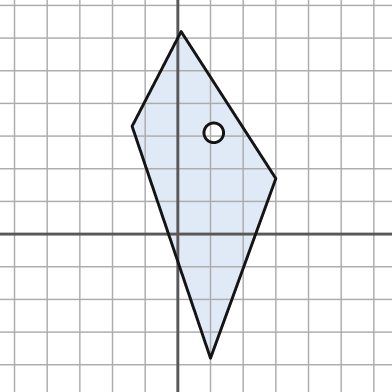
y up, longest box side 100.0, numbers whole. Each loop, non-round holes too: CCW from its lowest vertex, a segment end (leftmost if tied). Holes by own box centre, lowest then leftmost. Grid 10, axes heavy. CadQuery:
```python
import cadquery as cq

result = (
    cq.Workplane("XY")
    .moveTo(10.0, -38.0)
    .lineTo(30.0, 17.0)
    .lineTo(1.0, 62.0)
    .lineTo(-14.0, 33.0)
    .close()
    .moveTo(11.0, 31.0)
    .circle(3.0)
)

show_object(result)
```